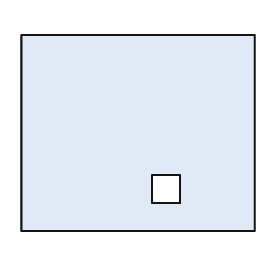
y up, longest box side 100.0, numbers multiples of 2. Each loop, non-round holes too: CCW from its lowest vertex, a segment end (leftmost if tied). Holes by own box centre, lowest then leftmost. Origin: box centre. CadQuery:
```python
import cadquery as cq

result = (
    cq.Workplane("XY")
    .moveTo(-50.0, -42.0)
    .lineTo(50.0, -42.0)
    .lineTo(50.0, 42.0)
    .lineTo(-50.0, 42.0)
    .close()
    .moveTo(6.0, -30.0)
    .lineTo(18.0, -30.0)
    .lineTo(18.0, -18.0)
    .lineTo(6.0, -18.0)
    .close()
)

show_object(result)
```